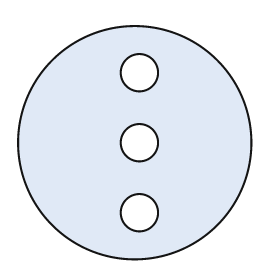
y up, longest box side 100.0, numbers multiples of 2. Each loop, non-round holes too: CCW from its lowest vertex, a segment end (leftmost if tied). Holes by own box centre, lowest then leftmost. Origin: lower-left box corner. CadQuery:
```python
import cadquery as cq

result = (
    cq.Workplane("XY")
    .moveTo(50.0, 50.0)
    .circle(50.0)
    .moveTo(52.0, 20.0)
    .circle(8.0)
    .moveTo(52.0, 50.0)
    .circle(8.0)
    .moveTo(52.0, 80.0)
    .circle(8.0)
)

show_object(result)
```